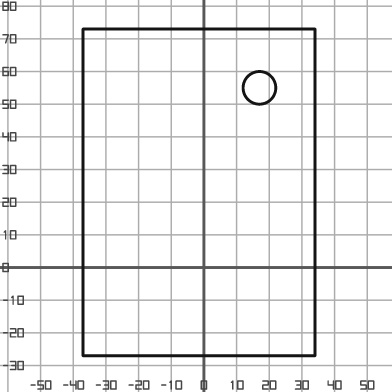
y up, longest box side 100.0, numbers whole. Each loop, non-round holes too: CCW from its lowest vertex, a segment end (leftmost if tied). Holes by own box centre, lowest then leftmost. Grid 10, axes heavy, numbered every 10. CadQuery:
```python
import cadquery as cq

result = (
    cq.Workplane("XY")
    .moveTo(-37.0, -27.0)
    .lineTo(34.0, -27.0)
    .lineTo(34.0, 73.0)
    .lineTo(-37.0, 73.0)
    .close()
    .moveTo(17.0, 55.0)
    .circle(5.0)
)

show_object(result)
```